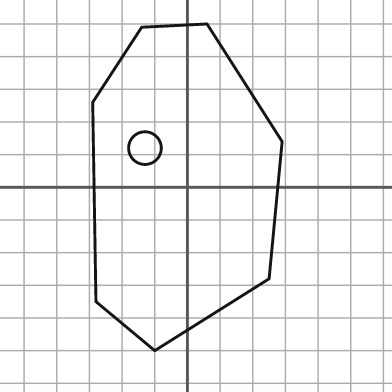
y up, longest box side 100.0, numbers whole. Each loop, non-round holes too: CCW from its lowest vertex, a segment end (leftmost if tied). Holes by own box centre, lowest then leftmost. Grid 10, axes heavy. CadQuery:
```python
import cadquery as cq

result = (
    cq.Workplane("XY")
    .moveTo(-10.0, -50.0)
    .lineTo(25.0, -28.0)
    .lineTo(29.0, 14.0)
    .lineTo(6.0, 50.0)
    .lineTo(-14.0, 49.0)
    .lineTo(-29.0, 26.0)
    .lineTo(-28.0, -35.0)
    .close()
    .moveTo(-13.0, 12.0)
    .circle(5.0)
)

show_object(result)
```